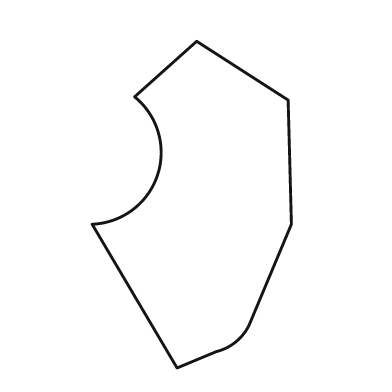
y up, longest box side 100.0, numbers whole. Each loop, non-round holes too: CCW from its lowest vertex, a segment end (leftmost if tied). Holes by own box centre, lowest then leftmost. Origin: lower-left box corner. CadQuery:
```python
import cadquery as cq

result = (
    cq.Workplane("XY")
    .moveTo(26.0, 0.0)
    .lineTo(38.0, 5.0)
    .threePointArc((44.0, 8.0), (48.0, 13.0))
    .lineTo(61.0, 44.0)
    .lineTo(60.0, 82.0)
    .lineTo(32.0, 100.0)
    .lineTo(13.0, 83.0)
    .threePointArc((20.0, 59.0), (0.0, 44.0))
    .close()
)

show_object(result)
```